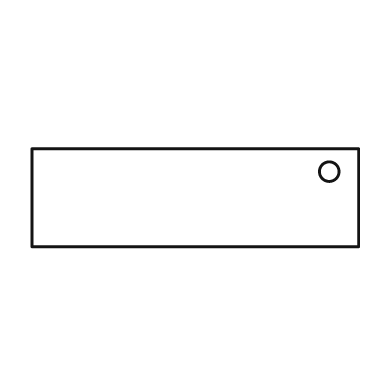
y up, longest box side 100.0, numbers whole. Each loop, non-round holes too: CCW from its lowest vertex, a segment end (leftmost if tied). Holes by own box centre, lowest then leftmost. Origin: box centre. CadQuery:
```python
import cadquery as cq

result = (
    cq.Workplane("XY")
    .moveTo(-50.0, -15.0)
    .lineTo(50.0, -15.0)
    .lineTo(50.0, 15.0)
    .lineTo(-50.0, 15.0)
    .close()
    .moveTo(41.0, 8.0)
    .circle(3.0)
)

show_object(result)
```